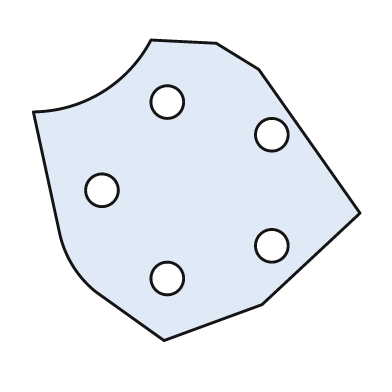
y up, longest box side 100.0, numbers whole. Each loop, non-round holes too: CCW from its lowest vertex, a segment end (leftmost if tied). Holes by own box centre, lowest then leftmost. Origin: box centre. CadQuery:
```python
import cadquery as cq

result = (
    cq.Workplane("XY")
    .moveTo(-10.0, -46.0)
    .lineTo(20.0, -35.0)
    .lineTo(50.0, -7.0)
    .lineTo(19.0, 37.0)
    .lineTo(6.0, 45.0)
    .lineTo(-14.0, 46.0)
    .threePointArc((-29.0, 30.0), (-50.0, 24.0))
    .lineTo(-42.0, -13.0)
    .threePointArc((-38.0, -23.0), (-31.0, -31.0))
    .close()
    .moveTo(-9.0, -27.0)
    .circle(5.0)
    .moveTo(23.0, -17.0)
    .circle(5.0)
    .moveTo(-29.0, 0.0)
    .circle(5.0)
    .moveTo(23.0, 17.0)
    .circle(5.0)
    .moveTo(-9.0, 27.0)
    .circle(5.0)
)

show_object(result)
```